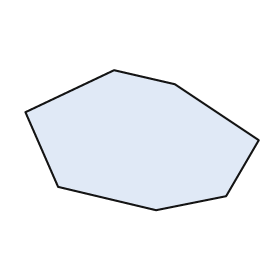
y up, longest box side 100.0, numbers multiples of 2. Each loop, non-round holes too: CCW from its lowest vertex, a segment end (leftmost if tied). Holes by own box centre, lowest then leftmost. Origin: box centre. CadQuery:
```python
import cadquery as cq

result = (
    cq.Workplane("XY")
    .moveTo(6.0, -30.0)
    .lineTo(36.0, -24.0)
    .lineTo(50.0, 0.0)
    .lineTo(14.0, 24.0)
    .lineTo(-12.0, 30.0)
    .lineTo(-50.0, 12.0)
    .lineTo(-36.0, -20.0)
    .close()
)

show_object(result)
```